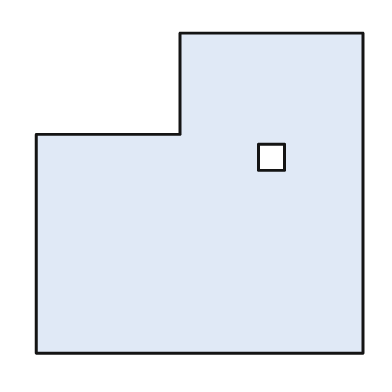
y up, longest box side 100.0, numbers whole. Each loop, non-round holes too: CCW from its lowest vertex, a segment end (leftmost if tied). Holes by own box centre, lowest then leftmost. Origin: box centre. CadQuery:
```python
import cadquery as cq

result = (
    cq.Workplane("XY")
    .moveTo(-50.0, -49.0)
    .lineTo(50.0, -49.0)
    .lineTo(50.0, 49.0)
    .lineTo(-6.0, 49.0)
    .lineTo(-6.0, 18.0)
    .lineTo(-50.0, 18.0)
    .close()
    .moveTo(18.0, 7.0)
    .lineTo(26.0, 7.0)
    .lineTo(26.0, 15.0)
    .lineTo(18.0, 15.0)
    .close()
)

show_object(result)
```